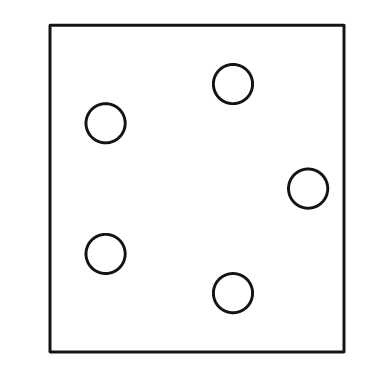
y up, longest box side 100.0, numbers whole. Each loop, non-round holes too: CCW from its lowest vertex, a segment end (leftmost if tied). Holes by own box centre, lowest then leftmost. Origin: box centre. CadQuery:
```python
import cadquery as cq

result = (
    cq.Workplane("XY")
    .moveTo(-45.0, -50.0)
    .lineTo(45.0, -50.0)
    .lineTo(45.0, 50.0)
    .lineTo(-45.0, 50.0)
    .close()
    .moveTo(11.0, -32.0)
    .circle(6.0)
    .moveTo(-28.0, -20.0)
    .circle(6.0)
    .moveTo(34.0, 0.0)
    .circle(6.0)
    .moveTo(-28.0, 20.0)
    .circle(6.0)
    .moveTo(11.0, 32.0)
    .circle(6.0)
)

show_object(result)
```